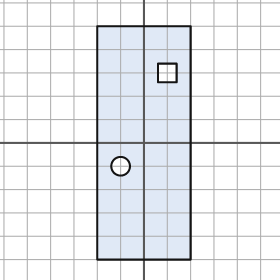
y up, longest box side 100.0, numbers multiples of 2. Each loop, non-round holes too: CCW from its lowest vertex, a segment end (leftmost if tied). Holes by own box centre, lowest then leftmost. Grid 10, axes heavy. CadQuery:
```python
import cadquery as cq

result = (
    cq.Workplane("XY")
    .moveTo(-20.0, -50.0)
    .lineTo(20.0, -50.0)
    .lineTo(20.0, 50.0)
    .lineTo(-20.0, 50.0)
    .close()
    .moveTo(-10.0, -10.0)
    .circle(4.0)
    .moveTo(6.0, 26.0)
    .lineTo(14.0, 26.0)
    .lineTo(14.0, 34.0)
    .lineTo(6.0, 34.0)
    .close()
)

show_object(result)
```